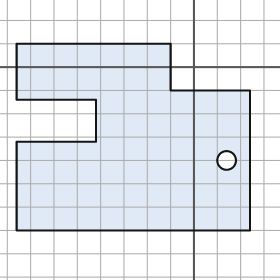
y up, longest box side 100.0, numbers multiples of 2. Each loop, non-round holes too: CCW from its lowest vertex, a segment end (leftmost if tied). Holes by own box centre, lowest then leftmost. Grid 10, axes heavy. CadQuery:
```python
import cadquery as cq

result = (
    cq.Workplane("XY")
    .moveTo(-76.0, -70.0)
    .lineTo(24.0, -70.0)
    .lineTo(24.0, -10.0)
    .lineTo(-10.0, -10.0)
    .lineTo(-10.0, 10.0)
    .lineTo(-76.0, 10.0)
    .lineTo(-76.0, -14.0)
    .lineTo(-42.0, -14.0)
    .lineTo(-42.0, -32.0)
    .lineTo(-76.0, -32.0)
    .close()
    .moveTo(14.0, -40.0)
    .circle(4.0)
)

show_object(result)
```